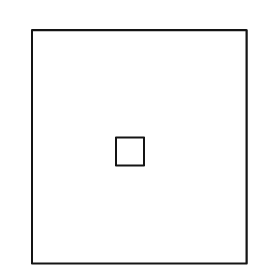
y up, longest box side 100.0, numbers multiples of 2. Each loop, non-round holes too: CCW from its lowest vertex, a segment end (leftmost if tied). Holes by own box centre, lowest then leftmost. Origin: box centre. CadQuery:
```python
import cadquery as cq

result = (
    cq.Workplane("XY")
    .moveTo(-46.0, -50.0)
    .lineTo(46.0, -50.0)
    .lineTo(46.0, 50.0)
    .lineTo(-46.0, 50.0)
    .close()
    .moveTo(-10.0, -8.0)
    .lineTo(2.0, -8.0)
    .lineTo(2.0, 4.0)
    .lineTo(-10.0, 4.0)
    .close()
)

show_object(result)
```